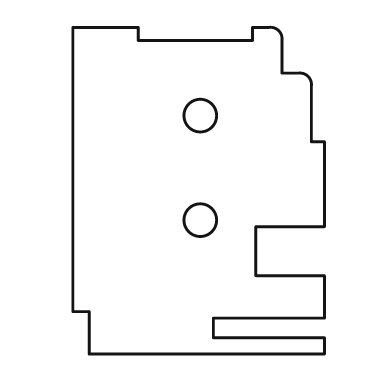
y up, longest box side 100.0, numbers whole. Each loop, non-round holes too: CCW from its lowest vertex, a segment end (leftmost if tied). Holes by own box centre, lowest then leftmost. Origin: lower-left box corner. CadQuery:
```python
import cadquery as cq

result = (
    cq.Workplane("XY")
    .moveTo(5.0, 0.0)
    .lineTo(77.0, 0.0)
    .lineTo(77.0, 5.0)
    .lineTo(43.0, 5.0)
    .lineTo(43.0, 11.0)
    .lineTo(77.0, 11.0)
    .lineTo(77.0, 24.0)
    .lineTo(56.0, 24.0)
    .lineTo(56.0, 39.0)
    .lineTo(77.0, 39.0)
    .lineTo(77.0, 65.0)
    .lineTo(73.0, 65.0)
    .lineTo(73.0, 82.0)
    .threePointArc((72.0, 85.0), (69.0, 86.0))
    .lineTo(64.0, 86.0)
    .lineTo(64.0, 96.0)
    .threePointArc((63.0, 99.0), (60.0, 100.0))
    .lineTo(55.0, 100.0)
    .lineTo(55.0, 96.0)
    .lineTo(20.0, 96.0)
    .lineTo(20.0, 100.0)
    .lineTo(0.0, 100.0)
    .lineTo(0.0, 13.0)
    .lineTo(5.0, 13.0)
    .close()
    .moveTo(39.0, 41.0)
    .circle(5.0)
    .moveTo(39.0, 73.0)
    .circle(5.0)
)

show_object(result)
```